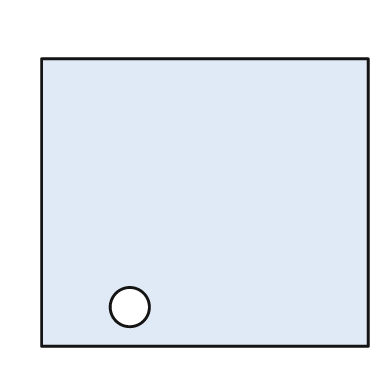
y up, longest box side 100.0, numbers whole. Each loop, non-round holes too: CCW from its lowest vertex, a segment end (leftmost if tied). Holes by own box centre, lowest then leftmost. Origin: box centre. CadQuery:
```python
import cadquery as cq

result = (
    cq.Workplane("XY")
    .moveTo(-50.0, -44.0)
    .lineTo(50.0, -44.0)
    .lineTo(50.0, 44.0)
    .lineTo(-50.0, 44.0)
    .close()
    .moveTo(-23.0, -32.0)
    .circle(6.0)
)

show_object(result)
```